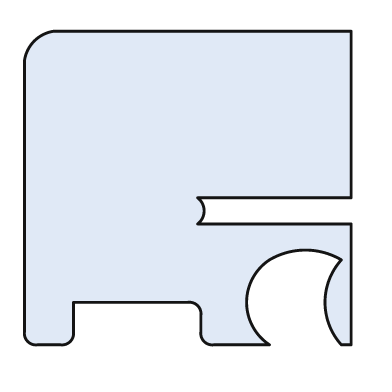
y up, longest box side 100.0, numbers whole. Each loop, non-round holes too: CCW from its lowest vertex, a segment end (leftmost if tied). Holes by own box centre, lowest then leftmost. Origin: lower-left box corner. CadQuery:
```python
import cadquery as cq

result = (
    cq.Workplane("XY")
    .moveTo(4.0, 0.0)
    .lineTo(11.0, 0.0)
    .threePointArc((14.0, 1.0), (15.0, 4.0))
    .lineTo(15.0, 13.0)
    .lineTo(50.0, 13.0)
    .threePointArc((53.0, 12.0), (54.0, 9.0))
    .lineTo(54.0, 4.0)
    .threePointArc((55.0, 1.0), (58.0, 0.0))
    .lineTo(75.0, 0.0)
    .threePointArc((68.0, 13.0), (75.0, 26.0))
    .threePointArc((86.0, 29.0), (97.0, 26.0))
    .threePointArc((92.0, 13.0), (97.0, 0.0))
    .lineTo(100.0, 0.0)
    .lineTo(100.0, 37.0)
    .lineTo(53.0, 37.0)
    .threePointArc((55.0, 41.0), (53.0, 45.0))
    .lineTo(100.0, 45.0)
    .lineTo(100.0, 96.0)
    .lineTo(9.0, 96.0)
    .threePointArc((3.0, 93.0), (0.0, 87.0))
    .lineTo(0.0, 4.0)
    .threePointArc((1.0, 1.0), (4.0, 0.0))
    .close()
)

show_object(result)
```